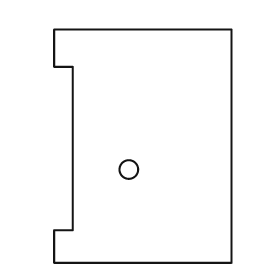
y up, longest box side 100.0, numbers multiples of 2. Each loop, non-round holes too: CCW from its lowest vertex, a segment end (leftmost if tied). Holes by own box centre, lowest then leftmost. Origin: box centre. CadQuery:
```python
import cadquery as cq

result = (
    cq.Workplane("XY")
    .moveTo(-38.0, -50.0)
    .lineTo(38.0, -50.0)
    .lineTo(38.0, 50.0)
    .lineTo(-38.0, 50.0)
    .lineTo(-38.0, 34.0)
    .lineTo(-30.0, 34.0)
    .lineTo(-30.0, -36.0)
    .lineTo(-38.0, -36.0)
    .close()
    .moveTo(-6.0, -10.0)
    .circle(4.0)
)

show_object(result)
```